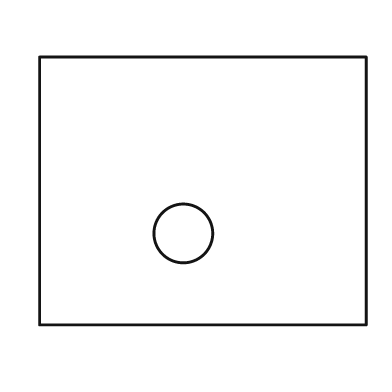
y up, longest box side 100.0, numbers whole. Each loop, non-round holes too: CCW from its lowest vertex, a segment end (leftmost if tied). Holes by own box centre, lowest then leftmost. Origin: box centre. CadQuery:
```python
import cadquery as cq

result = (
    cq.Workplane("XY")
    .moveTo(-50.0, -41.0)
    .lineTo(50.0, -41.0)
    .lineTo(50.0, 41.0)
    .lineTo(-50.0, 41.0)
    .close()
    .moveTo(-6.0, -13.0)
    .circle(9.0)
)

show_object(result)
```